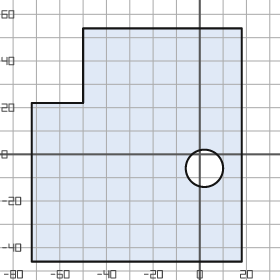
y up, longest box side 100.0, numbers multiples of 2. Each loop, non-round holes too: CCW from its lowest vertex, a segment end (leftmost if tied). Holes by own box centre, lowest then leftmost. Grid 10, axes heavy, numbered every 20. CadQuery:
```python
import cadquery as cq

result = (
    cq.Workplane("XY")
    .moveTo(-72.0, -46.0)
    .lineTo(18.0, -46.0)
    .lineTo(18.0, 54.0)
    .lineTo(-50.0, 54.0)
    .lineTo(-50.0, 22.0)
    .lineTo(-72.0, 22.0)
    .close()
    .moveTo(2.0, -6.0)
    .circle(8.0)
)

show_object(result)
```